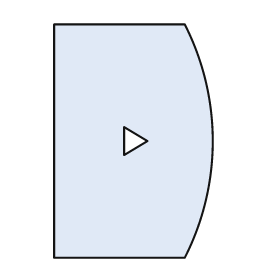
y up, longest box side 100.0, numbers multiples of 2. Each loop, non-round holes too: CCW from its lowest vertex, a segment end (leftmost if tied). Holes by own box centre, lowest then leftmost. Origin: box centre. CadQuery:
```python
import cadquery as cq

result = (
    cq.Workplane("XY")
    .moveTo(-34.0, -50.0)
    .lineTo(22.0, -50.0)
    .threePointArc((34.0, 0.0), (22.0, 50.0))
    .lineTo(-34.0, 50.0)
    .close()
    .moveTo(-4.0, -6.0)
    .lineTo(6.0, 0.0)
    .lineTo(-4.0, 6.0)
    .close()
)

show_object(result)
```